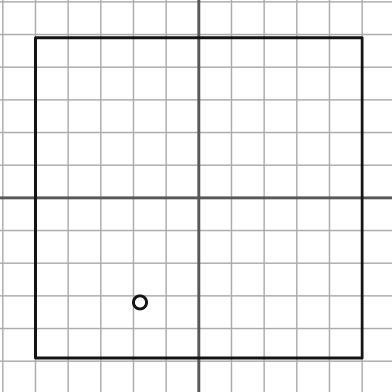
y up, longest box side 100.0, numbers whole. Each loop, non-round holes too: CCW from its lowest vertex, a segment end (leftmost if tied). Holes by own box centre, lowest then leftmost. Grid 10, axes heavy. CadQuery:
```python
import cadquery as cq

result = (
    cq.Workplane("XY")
    .moveTo(-50.0, -49.0)
    .lineTo(50.0, -49.0)
    .lineTo(50.0, 49.0)
    .lineTo(-50.0, 49.0)
    .close()
    .moveTo(-18.0, -32.0)
    .circle(2.0)
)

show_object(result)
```